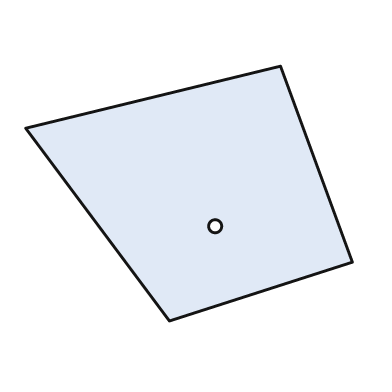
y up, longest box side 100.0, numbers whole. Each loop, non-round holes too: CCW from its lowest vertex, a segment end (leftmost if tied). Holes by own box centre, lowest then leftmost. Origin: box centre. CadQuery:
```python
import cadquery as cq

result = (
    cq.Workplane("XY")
    .moveTo(-6.0, -39.0)
    .lineTo(50.0, -21.0)
    .lineTo(28.0, 39.0)
    .lineTo(-50.0, 20.0)
    .close()
    .moveTo(8.0, -10.0)
    .circle(2.0)
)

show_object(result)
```